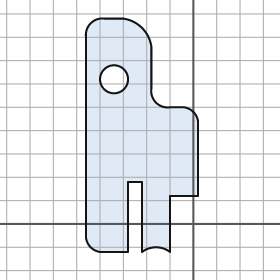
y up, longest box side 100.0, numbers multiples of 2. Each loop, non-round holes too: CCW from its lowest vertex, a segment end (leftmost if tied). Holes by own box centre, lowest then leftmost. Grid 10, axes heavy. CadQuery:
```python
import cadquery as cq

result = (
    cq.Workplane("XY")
    .moveTo(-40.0, -12.0)
    .lineTo(-28.0, -12.0)
    .lineTo(-28.0, 18.0)
    .lineTo(-22.0, 18.0)
    .lineTo(-22.0, -12.0)
    .threePointArc((-16.0, -10.0), (-10.0, -12.0))
    .lineTo(-10.0, 12.0)
    .lineTo(2.0, 12.0)
    .lineTo(2.0, 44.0)
    .threePointArc((0.0, 48.0), (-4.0, 50.0))
    .lineTo(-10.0, 50.0)
    .threePointArc((-16.0, 52.0), (-18.0, 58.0))
    .lineTo(-18.0, 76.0)
    .threePointArc((-22.0, 84.0), (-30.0, 88.0))
    .lineTo(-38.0, 88.0)
    .threePointArc((-44.0, 86.0), (-46.0, 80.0))
    .lineTo(-46.0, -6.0)
    .threePointArc((-44.0, -10.0), (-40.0, -12.0))
    .close()
    .moveTo(-34.0, 62.0)
    .circle(6.0)
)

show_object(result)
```